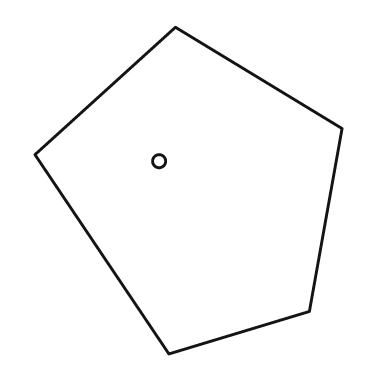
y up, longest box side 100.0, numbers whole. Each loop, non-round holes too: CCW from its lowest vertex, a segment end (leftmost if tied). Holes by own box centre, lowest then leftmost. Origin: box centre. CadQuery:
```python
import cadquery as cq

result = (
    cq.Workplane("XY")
    .moveTo(-6.0, -50.0)
    .lineTo(37.0, -37.0)
    .lineTo(47.0, 19.0)
    .lineTo(-4.0, 50.0)
    .lineTo(-47.0, 11.0)
    .close()
    .moveTo(-9.0, 9.0)
    .circle(2.0)
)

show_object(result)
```